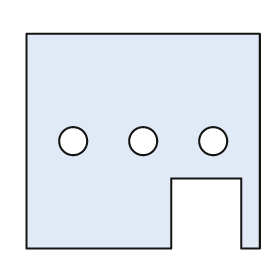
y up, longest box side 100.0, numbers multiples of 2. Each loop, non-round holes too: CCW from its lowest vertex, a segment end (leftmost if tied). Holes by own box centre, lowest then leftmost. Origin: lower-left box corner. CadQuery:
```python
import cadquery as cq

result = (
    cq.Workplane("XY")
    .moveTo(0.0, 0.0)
    .lineTo(62.0, 0.0)
    .lineTo(62.0, 30.0)
    .lineTo(92.0, 30.0)
    .lineTo(92.0, 0.0)
    .lineTo(100.0, 0.0)
    .lineTo(100.0, 92.0)
    .lineTo(0.0, 92.0)
    .close()
    .moveTo(20.0, 46.0)
    .circle(6.0)
    .moveTo(50.0, 46.0)
    .circle(6.0)
    .moveTo(80.0, 46.0)
    .circle(6.0)
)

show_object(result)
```